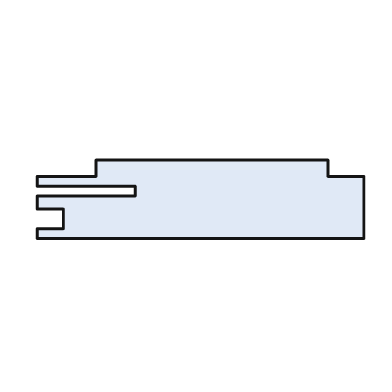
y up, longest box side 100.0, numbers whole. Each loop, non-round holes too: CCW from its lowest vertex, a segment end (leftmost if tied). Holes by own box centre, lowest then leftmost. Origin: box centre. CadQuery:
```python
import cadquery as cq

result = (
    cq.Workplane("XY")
    .moveTo(-50.0, -12.0)
    .lineTo(50.0, -12.0)
    .lineTo(50.0, 7.0)
    .lineTo(39.0, 7.0)
    .lineTo(39.0, 12.0)
    .lineTo(-32.0, 12.0)
    .lineTo(-32.0, 7.0)
    .lineTo(-50.0, 7.0)
    .lineTo(-50.0, 4.0)
    .lineTo(-20.0, 4.0)
    .lineTo(-20.0, 1.0)
    .lineTo(-50.0, 1.0)
    .lineTo(-50.0, -3.0)
    .lineTo(-42.0, -3.0)
    .lineTo(-42.0, -9.0)
    .lineTo(-50.0, -9.0)
    .close()
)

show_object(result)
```